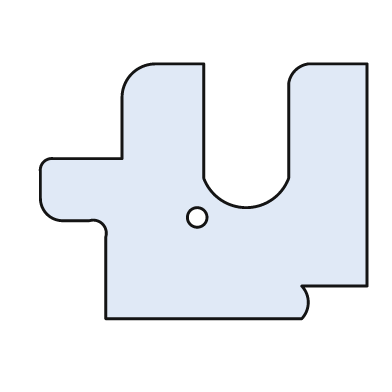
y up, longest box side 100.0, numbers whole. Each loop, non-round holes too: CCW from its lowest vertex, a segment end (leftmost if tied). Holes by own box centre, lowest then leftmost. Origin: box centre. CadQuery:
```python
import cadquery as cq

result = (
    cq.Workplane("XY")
    .moveTo(-30.0, -39.0)
    .lineTo(30.0, -39.0)
    .threePointArc((32.0, -34.0), (30.0, -29.0))
    .lineTo(50.0, -29.0)
    .lineTo(50.0, 39.0)
    .lineTo(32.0, 39.0)
    .threePointArc((28.0, 37.0), (26.0, 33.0))
    .lineTo(26.0, 4.0)
    .threePointArc((13.0, -5.0), (0.0, 4.0))
    .lineTo(0.0, 39.0)
    .lineTo(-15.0, 39.0)
    .threePointArc((-22.0, 36.0), (-25.0, 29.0))
    .lineTo(-25.0, 10.0)
    .lineTo(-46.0, 10.0)
    .threePointArc((-49.0, 9.0), (-50.0, 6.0))
    .lineTo(-50.0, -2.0)
    .threePointArc((-48.0, -7.0), (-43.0, -9.0))
    .lineTo(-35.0, -9.0)
    .threePointArc((-31.0, -10.0), (-30.0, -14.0))
    .close()
    .moveTo(-2.0, -8.0)
    .circle(3.0)
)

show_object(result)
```